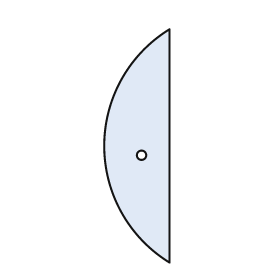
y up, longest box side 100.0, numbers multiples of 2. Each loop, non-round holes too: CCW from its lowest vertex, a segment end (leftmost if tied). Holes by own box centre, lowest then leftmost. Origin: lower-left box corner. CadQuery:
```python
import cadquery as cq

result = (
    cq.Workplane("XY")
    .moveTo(28.0, 0.0)
    .lineTo(28.0, 100.0)
    .threePointArc((0.0, 50.0), (28.0, 0.0))
    .close()
    .moveTo(16.0, 46.0)
    .circle(2.0)
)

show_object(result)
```